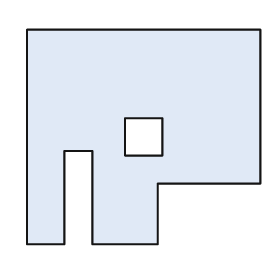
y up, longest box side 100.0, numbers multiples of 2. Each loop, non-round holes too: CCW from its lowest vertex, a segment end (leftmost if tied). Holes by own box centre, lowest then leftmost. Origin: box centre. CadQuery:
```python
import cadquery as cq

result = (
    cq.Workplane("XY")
    .moveTo(-50.0, -46.0)
    .lineTo(-34.0, -46.0)
    .lineTo(-34.0, -6.0)
    .lineTo(-22.0, -6.0)
    .lineTo(-22.0, -46.0)
    .lineTo(6.0, -46.0)
    .lineTo(6.0, -20.0)
    .lineTo(50.0, -20.0)
    .lineTo(50.0, 46.0)
    .lineTo(-50.0, 46.0)
    .close()
    .moveTo(-8.0, -8.0)
    .lineTo(8.0, -8.0)
    .lineTo(8.0, 8.0)
    .lineTo(-8.0, 8.0)
    .close()
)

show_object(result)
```